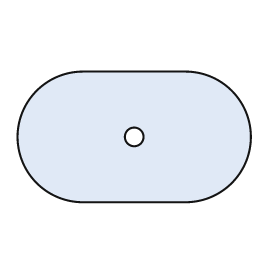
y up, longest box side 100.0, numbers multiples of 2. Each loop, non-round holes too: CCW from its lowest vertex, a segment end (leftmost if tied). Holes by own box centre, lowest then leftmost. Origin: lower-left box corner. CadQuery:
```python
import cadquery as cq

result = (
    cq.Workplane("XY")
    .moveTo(28.0, 0.0)
    .lineTo(72.0, 0.0)
    .threePointArc((100.0, 28.0), (72.0, 56.0))
    .lineTo(28.0, 56.0)
    .threePointArc((0.0, 28.0), (28.0, 0.0))
    .close()
    .moveTo(50.0, 28.0)
    .circle(4.0)
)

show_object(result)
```